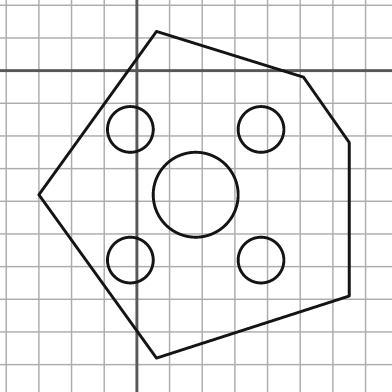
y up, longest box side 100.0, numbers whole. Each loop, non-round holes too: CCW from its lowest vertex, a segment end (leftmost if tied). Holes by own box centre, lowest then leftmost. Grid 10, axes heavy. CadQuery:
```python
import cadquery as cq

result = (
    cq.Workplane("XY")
    .moveTo(6.0, -88.0)
    .lineTo(65.0, -69.0)
    .lineTo(65.0, -22.0)
    .lineTo(51.0, -2.0)
    .lineTo(6.0, 12.0)
    .lineTo(-30.0, -38.0)
    .close()
    .moveTo(-2.0, -58.0)
    .circle(7.0)
    .moveTo(38.0, -58.0)
    .circle(7.0)
    .moveTo(18.0, -38.0)
    .circle(13.0)
    .moveTo(-2.0, -18.0)
    .circle(7.0)
    .moveTo(38.0, -18.0)
    .circle(7.0)
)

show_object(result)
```